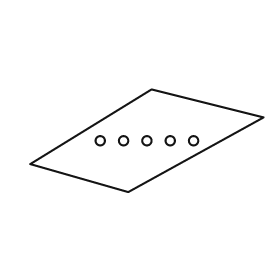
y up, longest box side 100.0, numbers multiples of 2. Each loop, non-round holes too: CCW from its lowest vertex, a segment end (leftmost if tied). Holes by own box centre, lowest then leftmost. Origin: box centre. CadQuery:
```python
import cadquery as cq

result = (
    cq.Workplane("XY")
    .moveTo(-8.0, -22.0)
    .lineTo(50.0, 10.0)
    .lineTo(2.0, 22.0)
    .lineTo(-50.0, -10.0)
    .close()
    .moveTo(-20.0, 0.0)
    .circle(2.0)
    .moveTo(-10.0, 0.0)
    .circle(2.0)
    .moveTo(0.0, 0.0)
    .circle(2.0)
    .moveTo(10.0, 0.0)
    .circle(2.0)
    .moveTo(20.0, 0.0)
    .circle(2.0)
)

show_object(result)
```